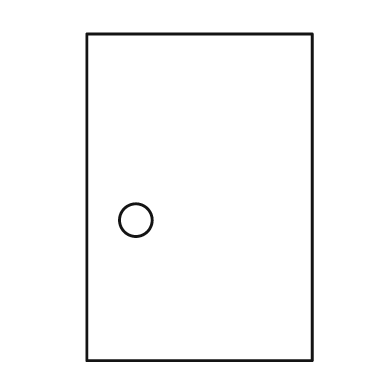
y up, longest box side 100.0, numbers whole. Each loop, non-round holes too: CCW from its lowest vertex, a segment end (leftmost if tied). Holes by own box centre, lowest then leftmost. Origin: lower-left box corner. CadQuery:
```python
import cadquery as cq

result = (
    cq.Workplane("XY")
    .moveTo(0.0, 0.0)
    .lineTo(69.0, 0.0)
    .lineTo(69.0, 100.0)
    .lineTo(0.0, 100.0)
    .close()
    .moveTo(15.0, 43.0)
    .circle(5.0)
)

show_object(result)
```